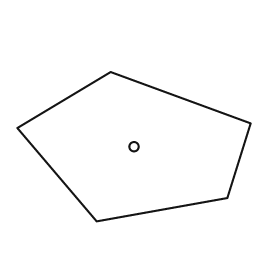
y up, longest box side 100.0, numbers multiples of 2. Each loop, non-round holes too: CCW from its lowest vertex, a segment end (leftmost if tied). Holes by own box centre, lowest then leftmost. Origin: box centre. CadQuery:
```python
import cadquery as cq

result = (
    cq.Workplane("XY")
    .moveTo(-16.0, -32.0)
    .lineTo(40.0, -22.0)
    .lineTo(50.0, 10.0)
    .lineTo(-10.0, 32.0)
    .lineTo(-50.0, 8.0)
    .close()
    .moveTo(0.0, 0.0)
    .circle(2.0)
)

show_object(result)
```